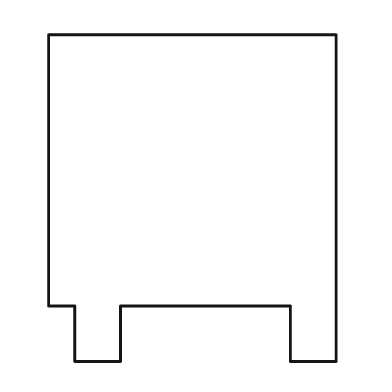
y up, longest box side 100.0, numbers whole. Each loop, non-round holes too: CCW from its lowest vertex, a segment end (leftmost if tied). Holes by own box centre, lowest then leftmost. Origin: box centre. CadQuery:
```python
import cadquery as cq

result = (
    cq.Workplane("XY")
    .moveTo(-36.0, -50.0)
    .lineTo(-22.0, -50.0)
    .lineTo(-22.0, -33.0)
    .lineTo(30.0, -33.0)
    .lineTo(30.0, -50.0)
    .lineTo(44.0, -50.0)
    .lineTo(44.0, 50.0)
    .lineTo(-44.0, 50.0)
    .lineTo(-44.0, -33.0)
    .lineTo(-36.0, -33.0)
    .close()
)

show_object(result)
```